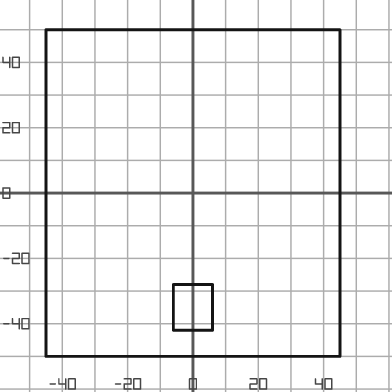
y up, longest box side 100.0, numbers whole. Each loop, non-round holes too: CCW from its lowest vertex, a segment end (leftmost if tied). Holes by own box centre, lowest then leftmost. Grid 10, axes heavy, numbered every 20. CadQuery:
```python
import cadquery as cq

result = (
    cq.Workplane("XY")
    .moveTo(-45.0, -50.0)
    .lineTo(45.0, -50.0)
    .lineTo(45.0, 50.0)
    .lineTo(-45.0, 50.0)
    .close()
    .moveTo(-6.0, -42.0)
    .lineTo(6.0, -42.0)
    .lineTo(6.0, -28.0)
    .lineTo(-6.0, -28.0)
    .close()
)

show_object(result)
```